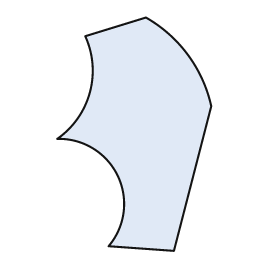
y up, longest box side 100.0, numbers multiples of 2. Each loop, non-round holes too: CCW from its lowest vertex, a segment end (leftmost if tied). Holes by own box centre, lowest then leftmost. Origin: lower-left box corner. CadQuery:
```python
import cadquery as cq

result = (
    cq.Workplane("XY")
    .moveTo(50.0, 0.0)
    .lineTo(66.0, 62.0)
    .threePointArc((56.0, 84.0), (38.0, 100.0))
    .lineTo(12.0, 92.0)
    .threePointArc((14.0, 68.0), (0.0, 48.0))
    .threePointArc((26.0, 32.0), (22.0, 2.0))
    .close()
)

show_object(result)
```